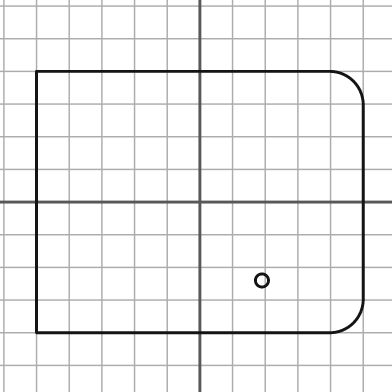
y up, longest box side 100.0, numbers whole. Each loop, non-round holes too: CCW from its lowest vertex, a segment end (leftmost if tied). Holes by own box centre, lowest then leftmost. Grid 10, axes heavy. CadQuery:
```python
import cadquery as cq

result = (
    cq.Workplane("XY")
    .moveTo(-50.0, -40.0)
    .lineTo(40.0, -40.0)
    .threePointArc((47.0, -37.0), (50.0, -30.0))
    .lineTo(50.0, 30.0)
    .threePointArc((47.0, 37.0), (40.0, 40.0))
    .lineTo(-50.0, 40.0)
    .close()
    .moveTo(19.0, -24.0)
    .circle(2.0)
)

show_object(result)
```